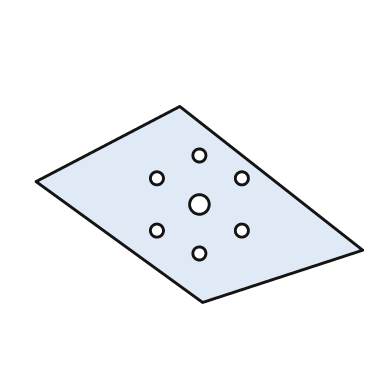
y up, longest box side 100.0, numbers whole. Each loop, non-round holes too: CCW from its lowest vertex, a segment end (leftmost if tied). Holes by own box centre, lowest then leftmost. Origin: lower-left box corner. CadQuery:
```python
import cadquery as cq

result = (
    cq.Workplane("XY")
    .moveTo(51.0, 0.0)
    .lineTo(100.0, 16.0)
    .lineTo(44.0, 60.0)
    .lineTo(0.0, 37.0)
    .close()
    .moveTo(50.0, 15.0)
    .circle(2.0)
    .moveTo(37.0, 22.0)
    .circle(2.0)
    .moveTo(63.0, 22.0)
    .circle(2.0)
    .moveTo(50.0, 30.0)
    .circle(3.0)
    .moveTo(37.0, 38.0)
    .circle(2.0)
    .moveTo(63.0, 38.0)
    .circle(2.0)
    .moveTo(50.0, 45.0)
    .circle(2.0)
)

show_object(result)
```